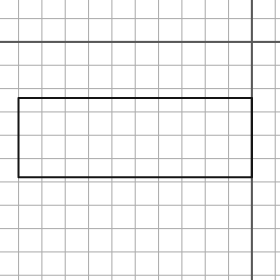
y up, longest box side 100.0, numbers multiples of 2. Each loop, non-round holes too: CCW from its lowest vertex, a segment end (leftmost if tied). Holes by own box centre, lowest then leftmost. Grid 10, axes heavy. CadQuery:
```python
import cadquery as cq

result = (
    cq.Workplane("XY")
    .moveTo(-100.0, -58.0)
    .lineTo(0.0, -58.0)
    .lineTo(0.0, -24.0)
    .lineTo(-100.0, -24.0)
    .close()
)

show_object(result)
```